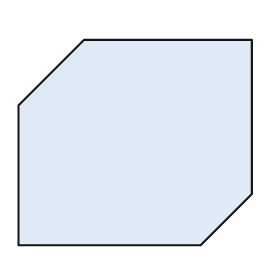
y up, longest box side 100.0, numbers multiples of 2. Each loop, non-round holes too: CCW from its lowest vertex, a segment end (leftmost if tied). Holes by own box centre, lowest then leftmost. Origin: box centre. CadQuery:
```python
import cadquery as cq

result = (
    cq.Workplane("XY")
    .moveTo(-50.0, -44.0)
    .lineTo(28.0, -44.0)
    .lineTo(50.0, -22.0)
    .lineTo(50.0, 44.0)
    .lineTo(-22.0, 44.0)
    .lineTo(-50.0, 16.0)
    .close()
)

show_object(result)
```